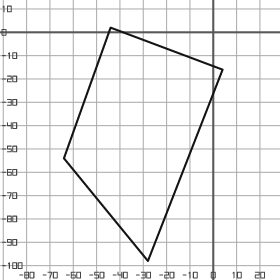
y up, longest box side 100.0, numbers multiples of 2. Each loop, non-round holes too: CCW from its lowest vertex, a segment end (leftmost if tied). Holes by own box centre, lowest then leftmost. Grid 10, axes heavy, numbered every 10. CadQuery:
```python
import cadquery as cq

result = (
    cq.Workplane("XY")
    .moveTo(-28.0, -98.0)
    .lineTo(4.0, -16.0)
    .lineTo(-44.0, 2.0)
    .lineTo(-64.0, -54.0)
    .close()
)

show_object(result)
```